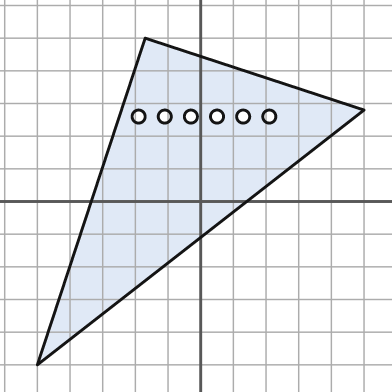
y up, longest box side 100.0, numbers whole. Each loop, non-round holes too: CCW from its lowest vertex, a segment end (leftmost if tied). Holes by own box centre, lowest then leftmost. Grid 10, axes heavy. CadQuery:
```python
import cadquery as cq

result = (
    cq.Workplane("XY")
    .moveTo(-50.0, -50.0)
    .lineTo(50.0, 28.0)
    .lineTo(-17.0, 50.0)
    .close()
    .moveTo(-19.0, 26.0)
    .circle(2.0)
    .moveTo(-11.0, 26.0)
    .circle(2.0)
    .moveTo(-3.0, 26.0)
    .circle(2.0)
    .moveTo(5.0, 26.0)
    .circle(2.0)
    .moveTo(13.0, 26.0)
    .circle(2.0)
    .moveTo(21.0, 26.0)
    .circle(2.0)
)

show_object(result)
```